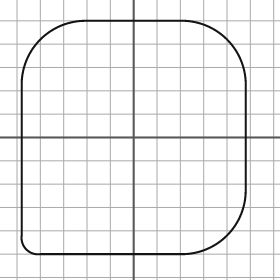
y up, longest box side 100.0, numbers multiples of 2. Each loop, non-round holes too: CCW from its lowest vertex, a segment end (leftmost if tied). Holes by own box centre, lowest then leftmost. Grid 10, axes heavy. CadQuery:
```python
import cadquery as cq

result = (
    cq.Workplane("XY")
    .moveTo(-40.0, -50.0)
    .lineTo(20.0, -50.0)
    .threePointArc((40.0, -42.0), (48.0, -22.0))
    .lineTo(48.0, 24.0)
    .threePointArc((40.0, 42.0), (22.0, 50.0))
    .lineTo(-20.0, 50.0)
    .threePointArc((-40.0, 42.0), (-48.0, 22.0))
    .lineTo(-48.0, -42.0)
    .threePointArc((-46.0, -48.0), (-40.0, -50.0))
    .close()
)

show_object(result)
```